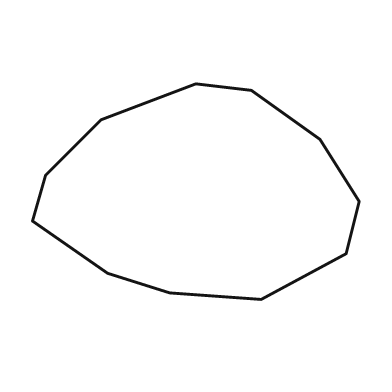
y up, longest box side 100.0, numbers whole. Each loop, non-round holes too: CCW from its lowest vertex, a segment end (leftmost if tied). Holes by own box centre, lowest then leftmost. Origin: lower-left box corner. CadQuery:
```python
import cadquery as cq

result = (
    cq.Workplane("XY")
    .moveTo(70.0, 0.0)
    .lineTo(96.0, 14.0)
    .lineTo(100.0, 30.0)
    .lineTo(88.0, 49.0)
    .lineTo(67.0, 64.0)
    .lineTo(50.0, 66.0)
    .lineTo(21.0, 55.0)
    .lineTo(4.0, 38.0)
    .lineTo(0.0, 24.0)
    .lineTo(23.0, 8.0)
    .lineTo(42.0, 2.0)
    .close()
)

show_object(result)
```